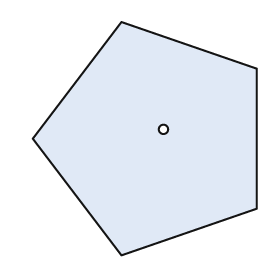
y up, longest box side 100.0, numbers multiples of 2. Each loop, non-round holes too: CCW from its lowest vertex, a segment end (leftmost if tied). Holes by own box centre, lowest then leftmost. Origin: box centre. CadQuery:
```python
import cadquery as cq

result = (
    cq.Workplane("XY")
    .moveTo(-10.0, -50.0)
    .lineTo(48.0, -30.0)
    .lineTo(48.0, 30.0)
    .lineTo(-10.0, 50.0)
    .lineTo(-48.0, 0.0)
    .close()
    .moveTo(8.0, 4.0)
    .circle(2.0)
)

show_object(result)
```